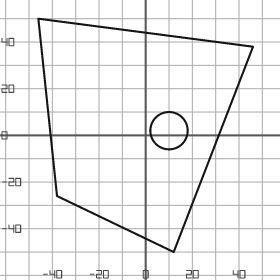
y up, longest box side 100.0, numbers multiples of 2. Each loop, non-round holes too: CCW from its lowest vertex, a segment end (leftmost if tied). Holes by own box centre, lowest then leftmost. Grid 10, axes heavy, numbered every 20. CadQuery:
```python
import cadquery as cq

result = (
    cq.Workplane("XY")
    .moveTo(12.0, -50.0)
    .lineTo(46.0, 38.0)
    .lineTo(-46.0, 50.0)
    .lineTo(-38.0, -26.0)
    .close()
    .moveTo(10.0, 2.0)
    .circle(8.0)
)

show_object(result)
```